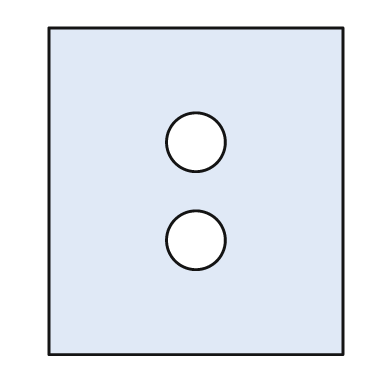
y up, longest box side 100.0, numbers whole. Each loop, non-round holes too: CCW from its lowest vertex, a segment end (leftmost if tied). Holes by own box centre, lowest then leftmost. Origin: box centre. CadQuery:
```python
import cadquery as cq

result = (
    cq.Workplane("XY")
    .moveTo(-45.0, -50.0)
    .lineTo(45.0, -50.0)
    .lineTo(45.0, 50.0)
    .lineTo(-45.0, 50.0)
    .close()
    .moveTo(0.0, -15.0)
    .circle(9.0)
    .moveTo(0.0, 15.0)
    .circle(9.0)
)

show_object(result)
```